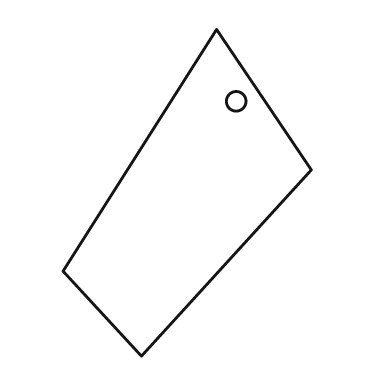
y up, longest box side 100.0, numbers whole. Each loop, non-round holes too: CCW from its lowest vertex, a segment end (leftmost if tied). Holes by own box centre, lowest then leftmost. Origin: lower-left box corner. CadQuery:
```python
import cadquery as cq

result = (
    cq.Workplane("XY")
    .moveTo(24.0, 0.0)
    .lineTo(76.0, 57.0)
    .lineTo(47.0, 100.0)
    .lineTo(0.0, 26.0)
    .close()
    .moveTo(53.0, 78.0)
    .circle(3.0)
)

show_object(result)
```